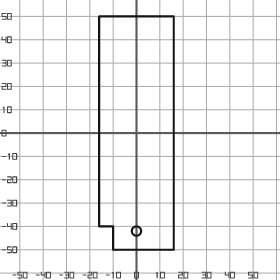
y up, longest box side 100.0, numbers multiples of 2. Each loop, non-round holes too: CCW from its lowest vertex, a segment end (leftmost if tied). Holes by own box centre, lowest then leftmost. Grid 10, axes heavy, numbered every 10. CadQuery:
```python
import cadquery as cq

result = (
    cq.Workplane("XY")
    .moveTo(-10.0, -50.0)
    .lineTo(16.0, -50.0)
    .lineTo(16.0, 50.0)
    .lineTo(-16.0, 50.0)
    .lineTo(-16.0, -40.0)
    .lineTo(-10.0, -40.0)
    .close()
    .moveTo(0.0, -42.0)
    .circle(2.0)
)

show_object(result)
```